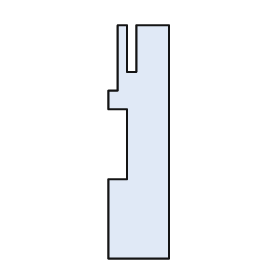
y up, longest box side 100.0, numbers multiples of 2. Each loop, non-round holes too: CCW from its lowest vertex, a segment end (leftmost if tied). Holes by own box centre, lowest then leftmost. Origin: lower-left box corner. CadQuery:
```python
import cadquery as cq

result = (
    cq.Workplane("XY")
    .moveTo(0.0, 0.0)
    .lineTo(26.0, 0.0)
    .lineTo(26.0, 100.0)
    .lineTo(12.0, 100.0)
    .lineTo(12.0, 80.0)
    .lineTo(8.0, 80.0)
    .lineTo(8.0, 100.0)
    .lineTo(4.0, 100.0)
    .lineTo(4.0, 72.0)
    .lineTo(0.0, 72.0)
    .lineTo(0.0, 64.0)
    .lineTo(8.0, 64.0)
    .lineTo(8.0, 34.0)
    .lineTo(0.0, 34.0)
    .close()
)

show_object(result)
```